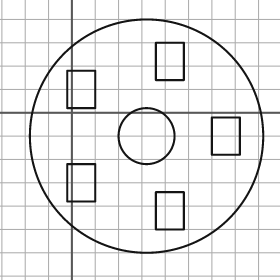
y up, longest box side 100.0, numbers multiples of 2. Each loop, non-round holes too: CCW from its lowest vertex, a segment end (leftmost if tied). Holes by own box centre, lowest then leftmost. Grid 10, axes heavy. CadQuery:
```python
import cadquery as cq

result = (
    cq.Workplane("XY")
    .moveTo(32.0, -10.0)
    .circle(50.0)
    .moveTo(36.0, -50.0)
    .lineTo(48.0, -50.0)
    .lineTo(48.0, -34.0)
    .lineTo(36.0, -34.0)
    .close()
    .moveTo(-2.0, -38.0)
    .lineTo(10.0, -38.0)
    .lineTo(10.0, -22.0)
    .lineTo(-2.0, -22.0)
    .close()
    .moveTo(32.0, -10.0)
    .circle(12.0)
    .moveTo(60.0, -18.0)
    .lineTo(72.0, -18.0)
    .lineTo(72.0, -2.0)
    .lineTo(60.0, -2.0)
    .close()
    .moveTo(-2.0, 2.0)
    .lineTo(10.0, 2.0)
    .lineTo(10.0, 18.0)
    .lineTo(-2.0, 18.0)
    .close()
    .moveTo(36.0, 14.0)
    .lineTo(48.0, 14.0)
    .lineTo(48.0, 30.0)
    .lineTo(36.0, 30.0)
    .close()
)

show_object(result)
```